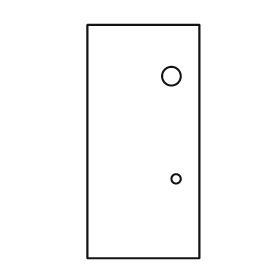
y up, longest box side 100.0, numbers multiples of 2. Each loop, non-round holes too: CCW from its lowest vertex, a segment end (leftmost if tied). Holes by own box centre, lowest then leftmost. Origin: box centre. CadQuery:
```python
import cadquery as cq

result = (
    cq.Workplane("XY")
    .moveTo(-24.0, -50.0)
    .lineTo(24.0, -50.0)
    .lineTo(24.0, 50.0)
    .lineTo(-24.0, 50.0)
    .close()
    .moveTo(14.0, -16.0)
    .circle(2.0)
    .moveTo(12.0, 28.0)
    .circle(4.0)
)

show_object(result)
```